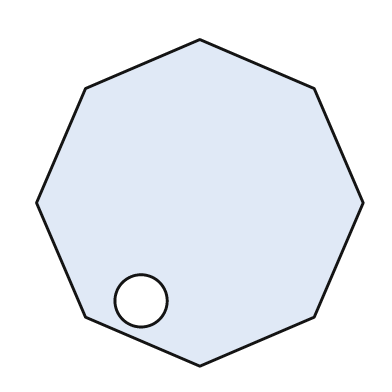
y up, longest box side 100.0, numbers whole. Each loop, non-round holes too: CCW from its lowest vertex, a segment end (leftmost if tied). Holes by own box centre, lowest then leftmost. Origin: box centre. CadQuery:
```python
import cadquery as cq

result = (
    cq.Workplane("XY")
    .moveTo(0.0, -50.0)
    .lineTo(35.0, -35.0)
    .lineTo(50.0, 0.0)
    .lineTo(35.0, 35.0)
    .lineTo(0.0, 50.0)
    .lineTo(-35.0, 35.0)
    .lineTo(-50.0, 0.0)
    .lineTo(-35.0, -35.0)
    .close()
    .moveTo(-18.0, -30.0)
    .circle(8.0)
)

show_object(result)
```